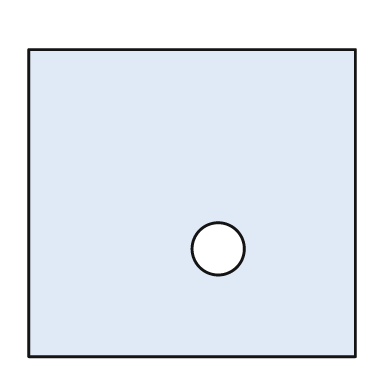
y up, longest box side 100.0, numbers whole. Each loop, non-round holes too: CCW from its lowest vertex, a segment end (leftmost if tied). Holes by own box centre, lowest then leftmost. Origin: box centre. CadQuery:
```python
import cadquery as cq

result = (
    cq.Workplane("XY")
    .moveTo(-50.0, -47.0)
    .lineTo(50.0, -47.0)
    .lineTo(50.0, 47.0)
    .lineTo(-50.0, 47.0)
    .close()
    .moveTo(8.0, -14.0)
    .circle(8.0)
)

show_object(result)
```